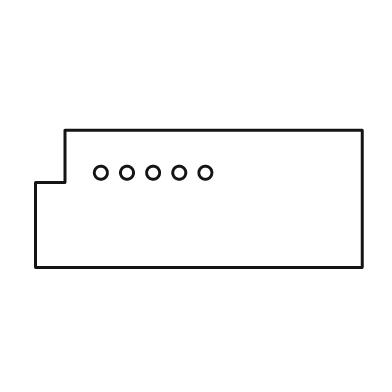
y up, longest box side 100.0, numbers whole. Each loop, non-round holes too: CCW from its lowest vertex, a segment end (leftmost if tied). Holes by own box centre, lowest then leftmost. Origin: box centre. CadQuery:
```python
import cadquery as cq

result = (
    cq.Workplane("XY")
    .moveTo(-50.0, -21.0)
    .lineTo(50.0, -21.0)
    .lineTo(50.0, 21.0)
    .lineTo(-41.0, 21.0)
    .lineTo(-41.0, 5.0)
    .lineTo(-50.0, 5.0)
    .close()
    .moveTo(-30.0, 8.0)
    .circle(2.0)
    .moveTo(-22.0, 8.0)
    .circle(2.0)
    .moveTo(-14.0, 8.0)
    .circle(2.0)
    .moveTo(-6.0, 8.0)
    .circle(2.0)
    .moveTo(2.0, 8.0)
    .circle(2.0)
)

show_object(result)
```